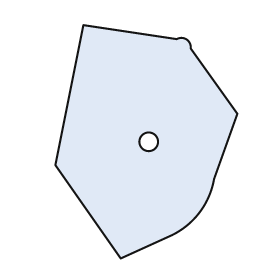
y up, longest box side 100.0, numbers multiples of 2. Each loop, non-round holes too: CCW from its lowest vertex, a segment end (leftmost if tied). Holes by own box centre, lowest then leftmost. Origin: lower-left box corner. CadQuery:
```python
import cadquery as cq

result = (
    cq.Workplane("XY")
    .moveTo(28.0, 0.0)
    .lineTo(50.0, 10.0)
    .threePointArc((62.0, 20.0), (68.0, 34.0))
    .lineTo(78.0, 62.0)
    .lineTo(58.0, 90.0)
    .threePointArc((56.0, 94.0), (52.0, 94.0))
    .lineTo(12.0, 100.0)
    .lineTo(0.0, 40.0)
    .close()
    .moveTo(40.0, 50.0)
    .circle(4.0)
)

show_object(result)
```